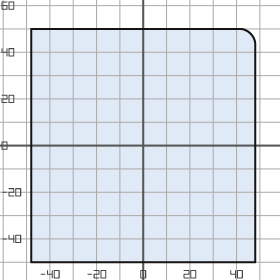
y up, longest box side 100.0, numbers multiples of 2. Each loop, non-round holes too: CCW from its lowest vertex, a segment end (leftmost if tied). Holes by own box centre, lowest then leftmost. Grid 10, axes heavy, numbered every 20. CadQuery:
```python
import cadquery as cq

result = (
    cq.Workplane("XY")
    .moveTo(-48.0, -50.0)
    .lineTo(48.0, -50.0)
    .lineTo(48.0, 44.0)
    .threePointArc((46.0, 48.0), (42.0, 50.0))
    .lineTo(-48.0, 50.0)
    .close()
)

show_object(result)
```